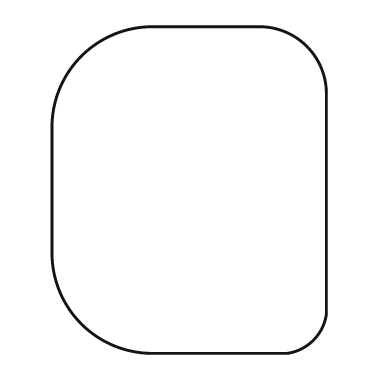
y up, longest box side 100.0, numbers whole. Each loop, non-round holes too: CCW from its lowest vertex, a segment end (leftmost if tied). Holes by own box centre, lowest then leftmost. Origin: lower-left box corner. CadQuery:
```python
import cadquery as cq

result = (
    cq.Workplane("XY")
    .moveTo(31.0, 0.0)
    .lineTo(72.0, 0.0)
    .threePointArc((80.0, 4.0), (84.0, 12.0))
    .lineTo(84.0, 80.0)
    .threePointArc((78.0, 94.0), (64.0, 100.0))
    .lineTo(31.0, 100.0)
    .threePointArc((9.0, 91.0), (0.0, 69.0))
    .lineTo(0.0, 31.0)
    .threePointArc((9.0, 9.0), (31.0, 0.0))
    .close()
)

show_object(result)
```